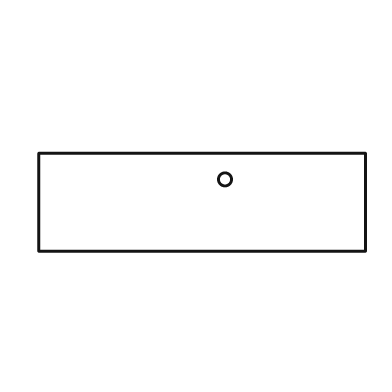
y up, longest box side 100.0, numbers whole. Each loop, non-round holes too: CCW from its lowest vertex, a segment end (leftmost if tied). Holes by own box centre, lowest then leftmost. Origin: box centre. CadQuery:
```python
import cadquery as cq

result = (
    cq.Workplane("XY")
    .moveTo(-50.0, -15.0)
    .lineTo(50.0, -15.0)
    .lineTo(50.0, 15.0)
    .lineTo(-50.0, 15.0)
    .close()
    .moveTo(7.0, 7.0)
    .circle(2.0)
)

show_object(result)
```